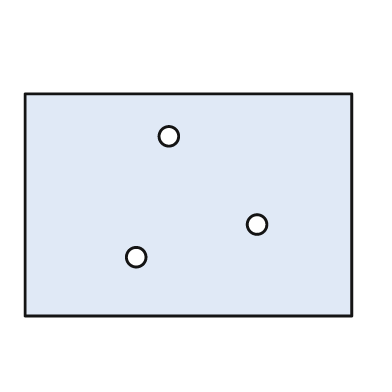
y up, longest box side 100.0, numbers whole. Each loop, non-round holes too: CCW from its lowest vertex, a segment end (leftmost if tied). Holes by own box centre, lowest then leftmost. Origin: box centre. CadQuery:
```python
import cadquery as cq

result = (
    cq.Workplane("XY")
    .moveTo(-50.0, -34.0)
    .lineTo(50.0, -34.0)
    .lineTo(50.0, 34.0)
    .lineTo(-50.0, 34.0)
    .close()
    .moveTo(-16.0, -16.0)
    .circle(3.0)
    .moveTo(21.0, -6.0)
    .circle(3.0)
    .moveTo(-6.0, 21.0)
    .circle(3.0)
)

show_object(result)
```